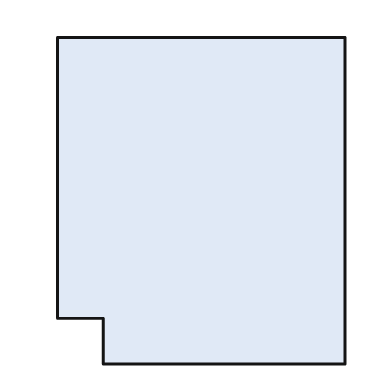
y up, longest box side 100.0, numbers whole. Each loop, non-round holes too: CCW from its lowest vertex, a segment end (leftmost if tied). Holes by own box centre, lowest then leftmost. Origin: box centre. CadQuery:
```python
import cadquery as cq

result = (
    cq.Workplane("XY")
    .moveTo(-30.0, -50.0)
    .lineTo(44.0, -50.0)
    .lineTo(44.0, 50.0)
    .lineTo(-44.0, 50.0)
    .lineTo(-44.0, -36.0)
    .lineTo(-30.0, -36.0)
    .close()
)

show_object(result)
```